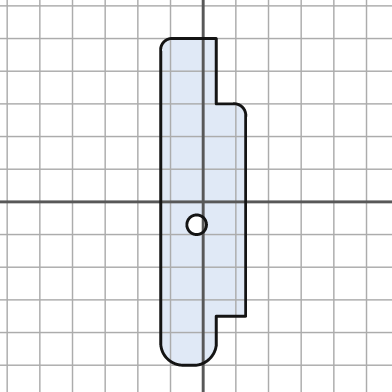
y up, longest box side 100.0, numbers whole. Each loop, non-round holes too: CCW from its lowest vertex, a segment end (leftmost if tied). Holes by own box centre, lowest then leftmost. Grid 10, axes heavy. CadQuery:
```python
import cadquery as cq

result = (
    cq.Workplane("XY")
    .moveTo(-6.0, -50.0)
    .lineTo(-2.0, -50.0)
    .threePointArc((2.0, -48.0), (4.0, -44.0))
    .lineTo(4.0, -35.0)
    .lineTo(13.0, -35.0)
    .lineTo(13.0, 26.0)
    .threePointArc((12.0, 29.0), (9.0, 30.0))
    .lineTo(4.0, 30.0)
    .lineTo(4.0, 50.0)
    .lineTo(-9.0, 50.0)
    .threePointArc((-12.0, 49.0), (-13.0, 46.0))
    .lineTo(-13.0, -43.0)
    .threePointArc((-11.0, -48.0), (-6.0, -50.0))
    .close()
    .moveTo(-2.0, -7.0)
    .circle(3.0)
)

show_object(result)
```